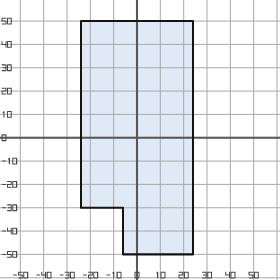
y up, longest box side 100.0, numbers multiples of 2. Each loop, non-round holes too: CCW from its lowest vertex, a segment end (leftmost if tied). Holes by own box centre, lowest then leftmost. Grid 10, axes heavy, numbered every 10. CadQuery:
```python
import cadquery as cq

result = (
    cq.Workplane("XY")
    .moveTo(-6.0, -50.0)
    .lineTo(24.0, -50.0)
    .lineTo(24.0, 50.0)
    .lineTo(-24.0, 50.0)
    .lineTo(-24.0, -30.0)
    .lineTo(-6.0, -30.0)
    .close()
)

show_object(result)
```